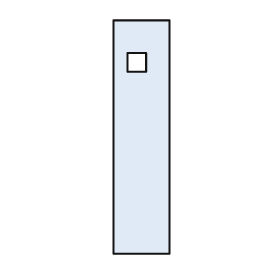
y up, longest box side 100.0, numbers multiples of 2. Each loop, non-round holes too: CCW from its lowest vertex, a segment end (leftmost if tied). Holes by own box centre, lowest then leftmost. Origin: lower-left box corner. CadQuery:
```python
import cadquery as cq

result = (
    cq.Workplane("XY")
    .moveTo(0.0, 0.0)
    .lineTo(24.0, 0.0)
    .lineTo(24.0, 100.0)
    .lineTo(0.0, 100.0)
    .close()
    .moveTo(6.0, 78.0)
    .lineTo(14.0, 78.0)
    .lineTo(14.0, 86.0)
    .lineTo(6.0, 86.0)
    .close()
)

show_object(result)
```